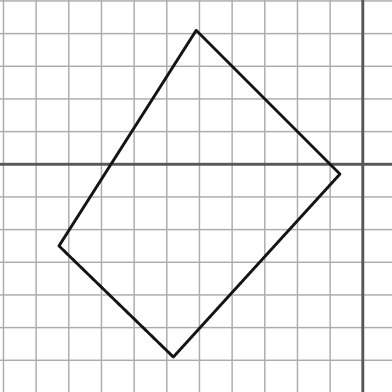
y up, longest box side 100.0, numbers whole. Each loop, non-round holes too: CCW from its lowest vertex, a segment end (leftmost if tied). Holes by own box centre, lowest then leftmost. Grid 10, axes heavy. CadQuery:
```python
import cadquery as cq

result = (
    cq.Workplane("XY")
    .moveTo(-58.0, -59.0)
    .lineTo(-7.0, -3.0)
    .lineTo(-51.0, 41.0)
    .lineTo(-93.0, -25.0)
    .close()
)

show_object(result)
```